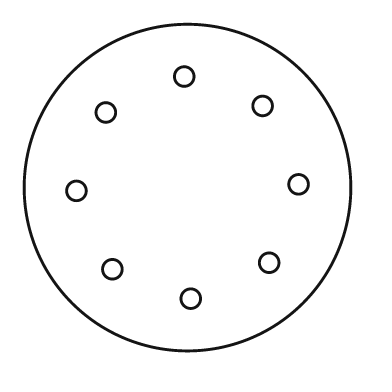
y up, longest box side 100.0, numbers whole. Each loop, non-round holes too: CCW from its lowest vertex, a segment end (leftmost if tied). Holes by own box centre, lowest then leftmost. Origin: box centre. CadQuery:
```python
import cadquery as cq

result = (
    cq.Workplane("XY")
    .moveTo(0.0, 0.0)
    .circle(50.0)
    .moveTo(1.0, -34.0)
    .circle(3.0)
    .moveTo(-23.0, -25.0)
    .circle(3.0)
    .moveTo(25.0, -23.0)
    .circle(3.0)
    .moveTo(-34.0, -1.0)
    .circle(3.0)
    .moveTo(34.0, 1.0)
    .circle(3.0)
    .moveTo(-25.0, 23.0)
    .circle(3.0)
    .moveTo(23.0, 25.0)
    .circle(3.0)
    .moveTo(-1.0, 34.0)
    .circle(3.0)
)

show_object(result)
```